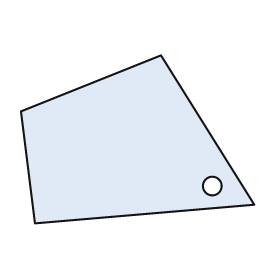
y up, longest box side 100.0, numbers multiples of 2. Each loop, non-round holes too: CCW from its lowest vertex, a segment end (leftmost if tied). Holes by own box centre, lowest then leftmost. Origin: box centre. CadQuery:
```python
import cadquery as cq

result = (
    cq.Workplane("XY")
    .moveTo(-44.0, -36.0)
    .lineTo(50.0, -28.0)
    .lineTo(10.0, 36.0)
    .lineTo(-50.0, 12.0)
    .close()
    .moveTo(32.0, -20.0)
    .circle(4.0)
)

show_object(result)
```